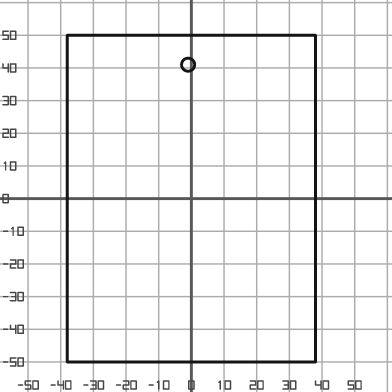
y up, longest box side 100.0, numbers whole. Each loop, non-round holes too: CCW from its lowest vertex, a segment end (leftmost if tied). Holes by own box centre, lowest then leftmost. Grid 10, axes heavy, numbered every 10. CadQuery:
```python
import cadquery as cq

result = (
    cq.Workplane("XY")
    .moveTo(-38.0, -50.0)
    .lineTo(38.0, -50.0)
    .lineTo(38.0, 50.0)
    .lineTo(-38.0, 50.0)
    .close()
    .moveTo(-1.0, 41.0)
    .circle(2.0)
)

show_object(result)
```